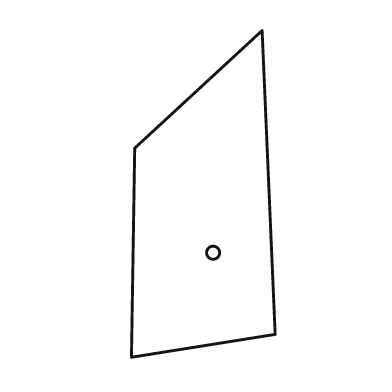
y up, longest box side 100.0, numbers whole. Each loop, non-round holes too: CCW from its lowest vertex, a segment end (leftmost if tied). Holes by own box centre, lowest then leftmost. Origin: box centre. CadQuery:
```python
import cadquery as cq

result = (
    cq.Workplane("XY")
    .moveTo(-22.0, -50.0)
    .lineTo(22.0, -43.0)
    .lineTo(18.0, 50.0)
    .lineTo(-21.0, 14.0)
    .close()
    .moveTo(3.0, -18.0)
    .circle(2.0)
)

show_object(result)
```